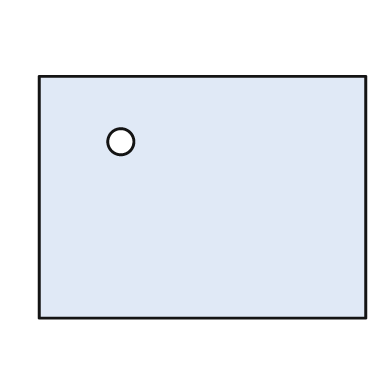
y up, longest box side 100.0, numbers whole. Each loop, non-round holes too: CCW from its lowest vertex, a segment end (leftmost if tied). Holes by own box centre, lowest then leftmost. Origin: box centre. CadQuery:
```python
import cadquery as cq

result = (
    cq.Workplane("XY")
    .moveTo(-50.0, -37.0)
    .lineTo(50.0, -37.0)
    .lineTo(50.0, 37.0)
    .lineTo(-50.0, 37.0)
    .close()
    .moveTo(-25.0, 17.0)
    .circle(4.0)
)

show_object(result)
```